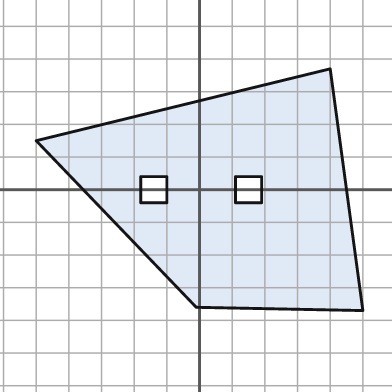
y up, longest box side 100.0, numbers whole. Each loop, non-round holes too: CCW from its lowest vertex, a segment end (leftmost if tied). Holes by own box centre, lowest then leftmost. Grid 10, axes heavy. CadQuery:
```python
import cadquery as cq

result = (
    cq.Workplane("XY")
    .moveTo(50.0, -37.0)
    .lineTo(40.0, 37.0)
    .lineTo(-50.0, 15.0)
    .lineTo(-1.0, -36.0)
    .close()
    .moveTo(-18.0, -4.0)
    .lineTo(-10.0, -4.0)
    .lineTo(-10.0, 4.0)
    .lineTo(-18.0, 4.0)
    .close()
    .moveTo(11.0, -4.0)
    .lineTo(19.0, -4.0)
    .lineTo(19.0, 4.0)
    .lineTo(11.0, 4.0)
    .close()
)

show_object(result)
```